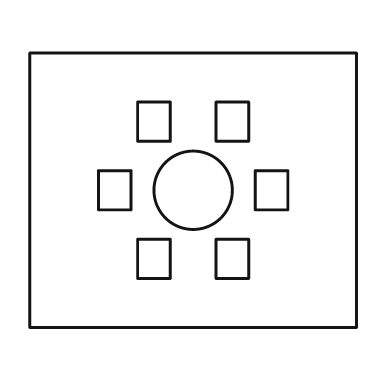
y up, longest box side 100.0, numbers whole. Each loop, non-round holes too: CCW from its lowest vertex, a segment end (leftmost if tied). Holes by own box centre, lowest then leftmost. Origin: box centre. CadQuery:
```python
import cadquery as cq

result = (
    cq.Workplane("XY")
    .moveTo(-50.0, -42.0)
    .lineTo(50.0, -42.0)
    .lineTo(50.0, 42.0)
    .lineTo(-50.0, 42.0)
    .close()
    .moveTo(-17.0, -27.0)
    .lineTo(-7.0, -27.0)
    .lineTo(-7.0, -15.0)
    .lineTo(-17.0, -15.0)
    .close()
    .moveTo(7.0, -27.0)
    .lineTo(17.0, -27.0)
    .lineTo(17.0, -15.0)
    .lineTo(7.0, -15.0)
    .close()
    .moveTo(-29.0, -6.0)
    .lineTo(-19.0, -6.0)
    .lineTo(-19.0, 6.0)
    .lineTo(-29.0, 6.0)
    .close()
    .moveTo(0.0, 0.0)
    .circle(12.0)
    .moveTo(19.0, -6.0)
    .lineTo(29.0, -6.0)
    .lineTo(29.0, 6.0)
    .lineTo(19.0, 6.0)
    .close()
    .moveTo(-17.0, 15.0)
    .lineTo(-7.0, 15.0)
    .lineTo(-7.0, 27.0)
    .lineTo(-17.0, 27.0)
    .close()
    .moveTo(7.0, 15.0)
    .lineTo(17.0, 15.0)
    .lineTo(17.0, 27.0)
    .lineTo(7.0, 27.0)
    .close()
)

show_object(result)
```